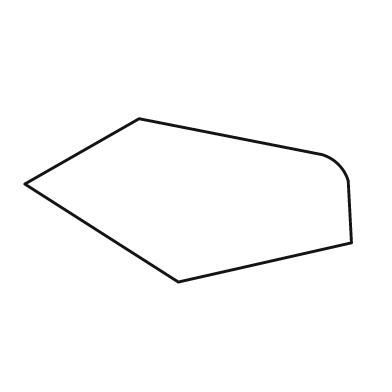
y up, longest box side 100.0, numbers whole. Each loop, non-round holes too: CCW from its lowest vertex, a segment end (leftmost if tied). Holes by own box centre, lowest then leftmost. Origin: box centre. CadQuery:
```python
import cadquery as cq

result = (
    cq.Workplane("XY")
    .moveTo(-3.0, -25.0)
    .lineTo(50.0, -13.0)
    .lineTo(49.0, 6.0)
    .threePointArc((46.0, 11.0), (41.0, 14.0))
    .lineTo(-15.0, 25.0)
    .lineTo(-50.0, 5.0)
    .close()
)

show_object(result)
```